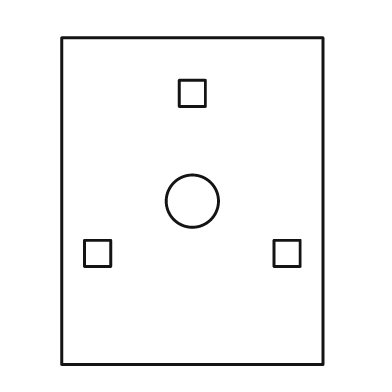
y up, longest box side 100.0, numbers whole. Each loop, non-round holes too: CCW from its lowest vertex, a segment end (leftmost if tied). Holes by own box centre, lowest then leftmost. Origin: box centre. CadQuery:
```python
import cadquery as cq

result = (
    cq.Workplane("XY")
    .moveTo(-40.0, -50.0)
    .lineTo(40.0, -50.0)
    .lineTo(40.0, 50.0)
    .lineTo(-40.0, 50.0)
    .close()
    .moveTo(-33.0, -20.0)
    .lineTo(-25.0, -20.0)
    .lineTo(-25.0, -12.0)
    .lineTo(-33.0, -12.0)
    .close()
    .moveTo(25.0, -20.0)
    .lineTo(33.0, -20.0)
    .lineTo(33.0, -12.0)
    .lineTo(25.0, -12.0)
    .close()
    .moveTo(0.0, 0.0)
    .circle(8.0)
    .moveTo(-4.0, 29.0)
    .lineTo(4.0, 29.0)
    .lineTo(4.0, 37.0)
    .lineTo(-4.0, 37.0)
    .close()
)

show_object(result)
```